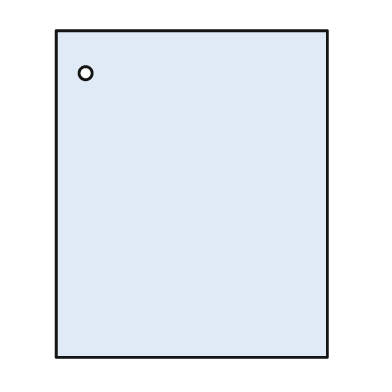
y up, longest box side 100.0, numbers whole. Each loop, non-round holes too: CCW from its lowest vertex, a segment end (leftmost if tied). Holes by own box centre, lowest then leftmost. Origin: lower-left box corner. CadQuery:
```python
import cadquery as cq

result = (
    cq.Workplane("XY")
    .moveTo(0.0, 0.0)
    .lineTo(83.0, 0.0)
    .lineTo(83.0, 100.0)
    .lineTo(0.0, 100.0)
    .close()
    .moveTo(9.0, 87.0)
    .circle(2.0)
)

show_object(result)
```